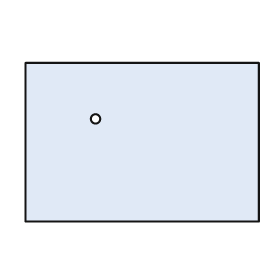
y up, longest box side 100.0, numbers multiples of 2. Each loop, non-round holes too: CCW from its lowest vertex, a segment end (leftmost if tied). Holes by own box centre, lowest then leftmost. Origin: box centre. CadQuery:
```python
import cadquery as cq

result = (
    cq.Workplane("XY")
    .moveTo(-50.0, -34.0)
    .lineTo(50.0, -34.0)
    .lineTo(50.0, 34.0)
    .lineTo(-50.0, 34.0)
    .close()
    .moveTo(-20.0, 10.0)
    .circle(2.0)
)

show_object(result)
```